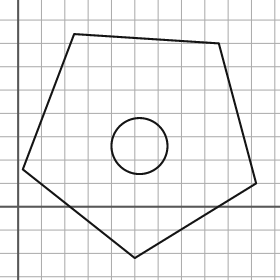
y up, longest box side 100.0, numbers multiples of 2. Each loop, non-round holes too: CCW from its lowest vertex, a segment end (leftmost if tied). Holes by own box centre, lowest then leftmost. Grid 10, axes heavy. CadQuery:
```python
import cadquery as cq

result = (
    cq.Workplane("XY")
    .moveTo(50.0, -22.0)
    .lineTo(102.0, 10.0)
    .lineTo(86.0, 70.0)
    .lineTo(24.0, 74.0)
    .lineTo(2.0, 16.0)
    .close()
    .moveTo(52.0, 26.0)
    .circle(12.0)
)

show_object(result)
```